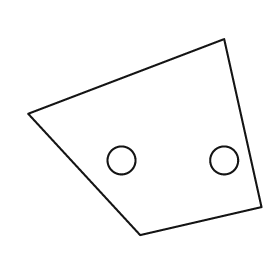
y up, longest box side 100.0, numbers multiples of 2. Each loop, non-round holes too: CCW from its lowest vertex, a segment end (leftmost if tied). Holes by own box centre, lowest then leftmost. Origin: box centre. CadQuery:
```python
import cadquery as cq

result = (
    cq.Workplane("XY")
    .moveTo(-2.0, -42.0)
    .lineTo(50.0, -30.0)
    .lineTo(34.0, 42.0)
    .lineTo(-50.0, 10.0)
    .close()
    .moveTo(-10.0, -10.0)
    .circle(6.0)
    .moveTo(34.0, -10.0)
    .circle(6.0)
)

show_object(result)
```